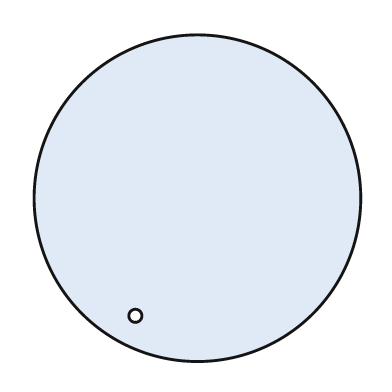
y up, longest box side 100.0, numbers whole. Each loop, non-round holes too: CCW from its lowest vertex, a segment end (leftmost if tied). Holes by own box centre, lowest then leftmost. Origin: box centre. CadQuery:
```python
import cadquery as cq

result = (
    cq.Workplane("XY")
    .moveTo(0.0, 0.0)
    .circle(50.0)
    .moveTo(-19.0, -36.0)
    .circle(2.0)
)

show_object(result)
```